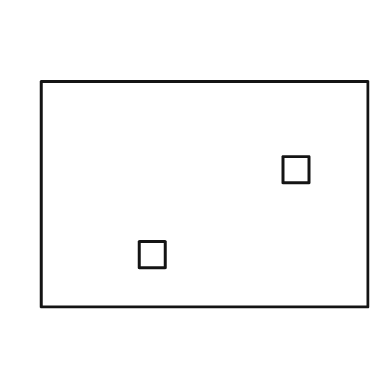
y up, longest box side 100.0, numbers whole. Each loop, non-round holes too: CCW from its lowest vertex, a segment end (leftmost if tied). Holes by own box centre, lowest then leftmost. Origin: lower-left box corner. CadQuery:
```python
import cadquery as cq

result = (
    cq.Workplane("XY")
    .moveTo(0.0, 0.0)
    .lineTo(100.0, 0.0)
    .lineTo(100.0, 69.0)
    .lineTo(0.0, 69.0)
    .close()
    .moveTo(30.0, 12.0)
    .lineTo(38.0, 12.0)
    .lineTo(38.0, 20.0)
    .lineTo(30.0, 20.0)
    .close()
    .moveTo(74.0, 38.0)
    .lineTo(82.0, 38.0)
    .lineTo(82.0, 46.0)
    .lineTo(74.0, 46.0)
    .close()
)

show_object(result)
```